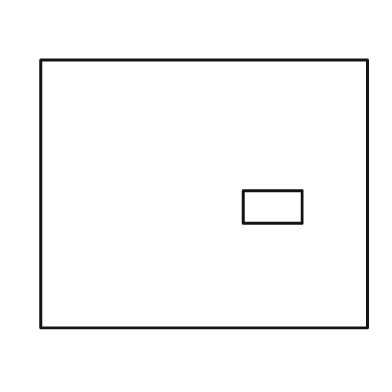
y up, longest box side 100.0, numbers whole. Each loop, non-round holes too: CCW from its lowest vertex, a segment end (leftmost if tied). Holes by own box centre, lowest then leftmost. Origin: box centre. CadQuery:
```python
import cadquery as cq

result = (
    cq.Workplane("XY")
    .moveTo(-50.0, -41.0)
    .lineTo(50.0, -41.0)
    .lineTo(50.0, 41.0)
    .lineTo(-50.0, 41.0)
    .close()
    .moveTo(12.0, -9.0)
    .lineTo(30.0, -9.0)
    .lineTo(30.0, 1.0)
    .lineTo(12.0, 1.0)
    .close()
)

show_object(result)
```